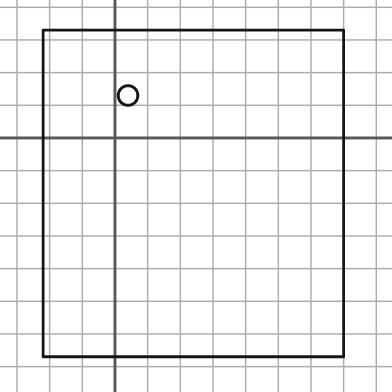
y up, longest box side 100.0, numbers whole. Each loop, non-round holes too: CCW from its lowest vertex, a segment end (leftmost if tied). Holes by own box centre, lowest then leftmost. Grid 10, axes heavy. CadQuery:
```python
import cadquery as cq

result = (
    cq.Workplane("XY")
    .moveTo(-22.0, -67.0)
    .lineTo(70.0, -67.0)
    .lineTo(70.0, 33.0)
    .lineTo(-22.0, 33.0)
    .close()
    .moveTo(4.0, 13.0)
    .circle(3.0)
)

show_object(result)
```